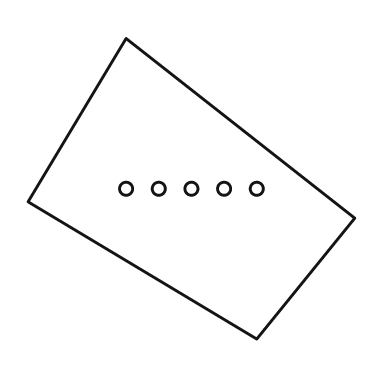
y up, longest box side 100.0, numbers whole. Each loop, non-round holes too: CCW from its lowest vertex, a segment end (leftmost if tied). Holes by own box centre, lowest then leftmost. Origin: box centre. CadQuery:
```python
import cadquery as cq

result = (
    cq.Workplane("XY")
    .moveTo(20.0, -46.0)
    .lineTo(50.0, -9.0)
    .lineTo(-20.0, 46.0)
    .lineTo(-50.0, -4.0)
    .close()
    .moveTo(-20.0, 0.0)
    .circle(2.0)
    .moveTo(-10.0, 0.0)
    .circle(2.0)
    .moveTo(0.0, 0.0)
    .circle(2.0)
    .moveTo(10.0, 0.0)
    .circle(2.0)
    .moveTo(20.0, 0.0)
    .circle(2.0)
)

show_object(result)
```